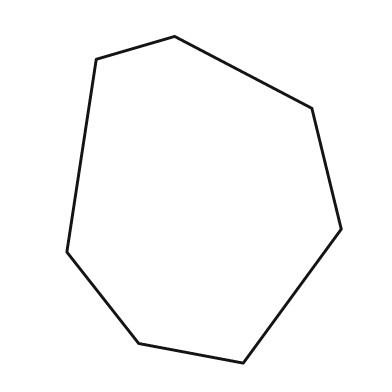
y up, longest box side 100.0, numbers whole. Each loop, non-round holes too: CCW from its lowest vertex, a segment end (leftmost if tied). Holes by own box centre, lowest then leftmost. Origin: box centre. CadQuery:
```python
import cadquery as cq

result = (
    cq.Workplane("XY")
    .moveTo(12.0, -50.0)
    .lineTo(42.0, -9.0)
    .lineTo(33.0, 28.0)
    .lineTo(-9.0, 50.0)
    .lineTo(-33.0, 43.0)
    .lineTo(-42.0, -16.0)
    .lineTo(-20.0, -44.0)
    .close()
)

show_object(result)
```